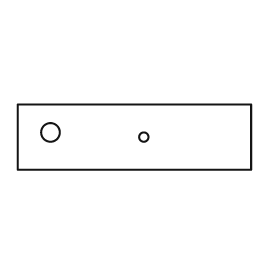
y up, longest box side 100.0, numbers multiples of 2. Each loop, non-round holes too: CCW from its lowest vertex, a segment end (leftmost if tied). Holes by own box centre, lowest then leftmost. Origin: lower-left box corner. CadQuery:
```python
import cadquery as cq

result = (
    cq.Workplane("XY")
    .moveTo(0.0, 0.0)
    .lineTo(100.0, 0.0)
    .lineTo(100.0, 28.0)
    .lineTo(0.0, 28.0)
    .close()
    .moveTo(54.0, 14.0)
    .circle(2.0)
    .moveTo(14.0, 16.0)
    .circle(4.0)
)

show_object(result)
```